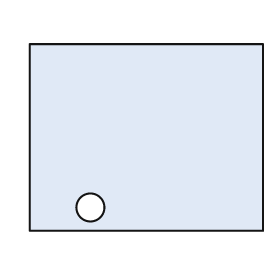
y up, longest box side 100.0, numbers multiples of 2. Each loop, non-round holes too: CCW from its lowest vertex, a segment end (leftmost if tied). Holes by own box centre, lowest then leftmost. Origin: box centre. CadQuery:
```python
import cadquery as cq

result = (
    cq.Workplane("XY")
    .moveTo(-50.0, -40.0)
    .lineTo(50.0, -40.0)
    .lineTo(50.0, 40.0)
    .lineTo(-50.0, 40.0)
    .close()
    .moveTo(-24.0, -30.0)
    .circle(6.0)
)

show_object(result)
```